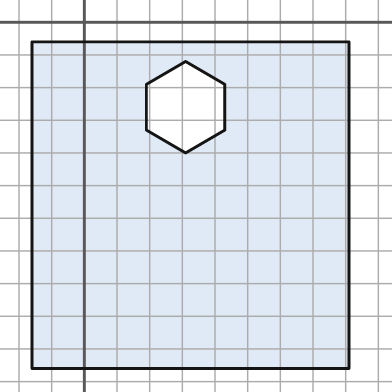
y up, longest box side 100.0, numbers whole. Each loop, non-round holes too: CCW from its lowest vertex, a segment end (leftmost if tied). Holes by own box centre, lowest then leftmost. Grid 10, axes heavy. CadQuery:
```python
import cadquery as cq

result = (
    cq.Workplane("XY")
    .moveTo(-16.0, -106.0)
    .lineTo(81.0, -106.0)
    .lineTo(81.0, -6.0)
    .lineTo(-16.0, -6.0)
    .close()
    .moveTo(31.0, -40.0)
    .lineTo(43.0, -33.0)
    .lineTo(43.0, -19.0)
    .lineTo(31.0, -12.0)
    .lineTo(19.0, -19.0)
    .lineTo(19.0, -33.0)
    .close()
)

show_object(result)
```